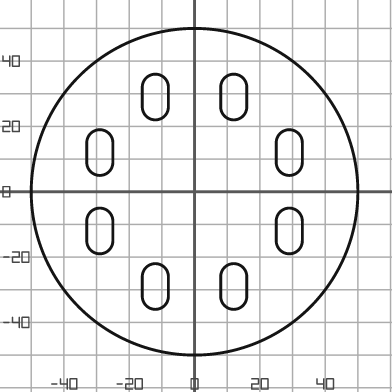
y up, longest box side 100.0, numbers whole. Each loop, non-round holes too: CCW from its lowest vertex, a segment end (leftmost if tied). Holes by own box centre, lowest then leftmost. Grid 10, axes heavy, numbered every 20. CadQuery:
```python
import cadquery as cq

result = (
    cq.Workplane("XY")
    .moveTo(0.0, 0.0)
    .circle(50.0)
    .moveTo(-16.0, -32.0)
    .threePointArc((-12.0, -36.0), (-8.0, -32.0))
    .lineTo(-8.0, -26.0)
    .threePointArc((-12.0, -22.0), (-16.0, -26.0))
    .close()
    .moveTo(8.0, -32.0)
    .threePointArc((12.0, -36.0), (16.0, -32.0))
    .lineTo(16.0, -26.0)
    .threePointArc((12.0, -22.0), (8.0, -26.0))
    .close()
    .moveTo(-33.0, -15.0)
    .threePointArc((-29.0, -19.0), (-25.0, -15.0))
    .lineTo(-25.0, -9.0)
    .threePointArc((-29.0, -5.0), (-33.0, -9.0))
    .close()
    .moveTo(25.0, -15.0)
    .threePointArc((29.0, -19.0), (33.0, -15.0))
    .lineTo(33.0, -9.0)
    .threePointArc((29.0, -5.0), (25.0, -9.0))
    .close()
    .moveTo(-33.0, 9.0)
    .threePointArc((-29.0, 5.0), (-25.0, 9.0))
    .lineTo(-25.0, 15.0)
    .threePointArc((-29.0, 19.0), (-33.0, 15.0))
    .close()
    .moveTo(25.0, 9.0)
    .threePointArc((29.0, 5.0), (33.0, 9.0))
    .lineTo(33.0, 15.0)
    .threePointArc((29.0, 19.0), (25.0, 15.0))
    .close()
    .moveTo(-16.0, 26.0)
    .threePointArc((-12.0, 22.0), (-8.0, 26.0))
    .lineTo(-8.0, 32.0)
    .threePointArc((-12.0, 36.0), (-16.0, 32.0))
    .close()
    .moveTo(8.0, 26.0)
    .threePointArc((12.0, 22.0), (16.0, 26.0))
    .lineTo(16.0, 32.0)
    .threePointArc((12.0, 36.0), (8.0, 32.0))
    .close()
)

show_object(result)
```